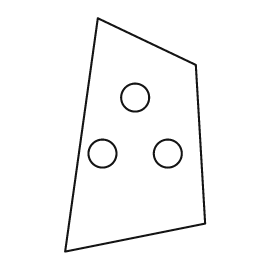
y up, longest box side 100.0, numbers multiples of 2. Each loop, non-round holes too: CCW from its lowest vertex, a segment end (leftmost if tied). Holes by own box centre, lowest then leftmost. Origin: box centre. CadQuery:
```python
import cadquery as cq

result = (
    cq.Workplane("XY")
    .moveTo(-30.0, -50.0)
    .lineTo(30.0, -38.0)
    .lineTo(26.0, 30.0)
    .lineTo(-16.0, 50.0)
    .close()
    .moveTo(-14.0, -8.0)
    .circle(6.0)
    .moveTo(14.0, -8.0)
    .circle(6.0)
    .moveTo(0.0, 16.0)
    .circle(6.0)
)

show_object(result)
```